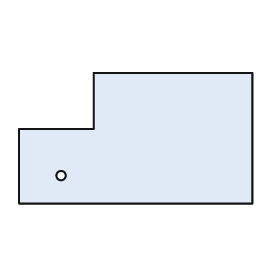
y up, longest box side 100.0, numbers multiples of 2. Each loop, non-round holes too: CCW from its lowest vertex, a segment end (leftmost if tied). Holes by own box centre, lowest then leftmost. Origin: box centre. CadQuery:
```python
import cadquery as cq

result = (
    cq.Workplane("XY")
    .moveTo(-50.0, -28.0)
    .lineTo(50.0, -28.0)
    .lineTo(50.0, 28.0)
    .lineTo(-18.0, 28.0)
    .lineTo(-18.0, 4.0)
    .lineTo(-50.0, 4.0)
    .close()
    .moveTo(-32.0, -16.0)
    .circle(2.0)
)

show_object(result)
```